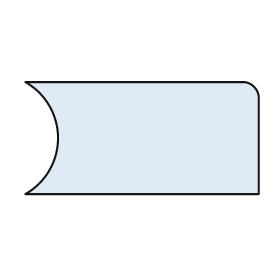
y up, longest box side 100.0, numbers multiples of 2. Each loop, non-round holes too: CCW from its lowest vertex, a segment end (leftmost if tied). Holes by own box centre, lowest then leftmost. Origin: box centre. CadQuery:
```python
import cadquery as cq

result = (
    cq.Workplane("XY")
    .moveTo(-50.0, -24.0)
    .lineTo(50.0, -24.0)
    .lineTo(50.0, 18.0)
    .threePointArc((48.0, 22.0), (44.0, 24.0))
    .lineTo(-50.0, 24.0)
    .threePointArc((-36.0, 0.0), (-50.0, -24.0))
    .close()
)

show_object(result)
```